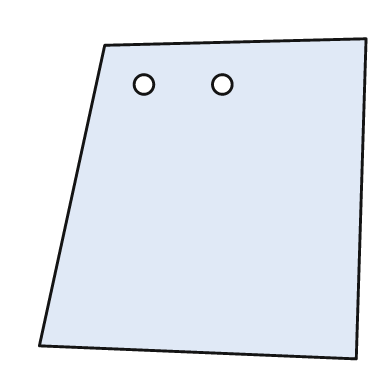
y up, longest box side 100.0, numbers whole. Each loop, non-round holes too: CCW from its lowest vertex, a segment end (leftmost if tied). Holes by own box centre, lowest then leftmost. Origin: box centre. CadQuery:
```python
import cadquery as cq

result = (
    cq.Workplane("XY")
    .moveTo(47.0, -49.0)
    .lineTo(50.0, 49.0)
    .lineTo(-30.0, 47.0)
    .lineTo(-50.0, -45.0)
    .close()
    .moveTo(-18.0, 35.0)
    .circle(3.0)
    .moveTo(6.0, 35.0)
    .circle(3.0)
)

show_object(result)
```